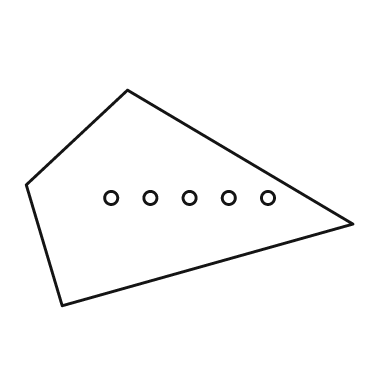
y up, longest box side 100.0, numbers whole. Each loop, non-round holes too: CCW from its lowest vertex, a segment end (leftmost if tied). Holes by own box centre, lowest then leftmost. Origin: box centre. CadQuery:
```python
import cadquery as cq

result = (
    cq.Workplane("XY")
    .moveTo(-39.0, -33.0)
    .lineTo(50.0, -8.0)
    .lineTo(-19.0, 33.0)
    .lineTo(-50.0, 4.0)
    .close()
    .moveTo(-24.0, 0.0)
    .circle(2.0)
    .moveTo(-12.0, 0.0)
    .circle(2.0)
    .moveTo(0.0, 0.0)
    .circle(2.0)
    .moveTo(12.0, 0.0)
    .circle(2.0)
    .moveTo(24.0, 0.0)
    .circle(2.0)
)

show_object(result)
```